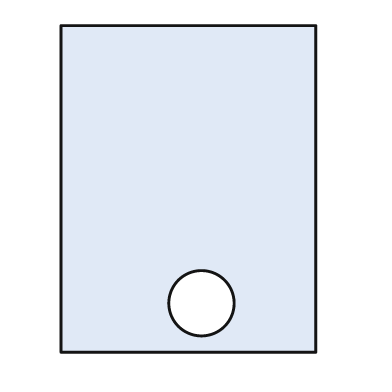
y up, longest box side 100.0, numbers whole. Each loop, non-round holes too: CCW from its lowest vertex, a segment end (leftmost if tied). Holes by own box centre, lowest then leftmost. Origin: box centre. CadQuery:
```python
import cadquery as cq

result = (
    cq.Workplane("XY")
    .moveTo(-39.0, -50.0)
    .lineTo(39.0, -50.0)
    .lineTo(39.0, 50.0)
    .lineTo(-39.0, 50.0)
    .close()
    .moveTo(4.0, -35.0)
    .circle(10.0)
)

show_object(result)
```